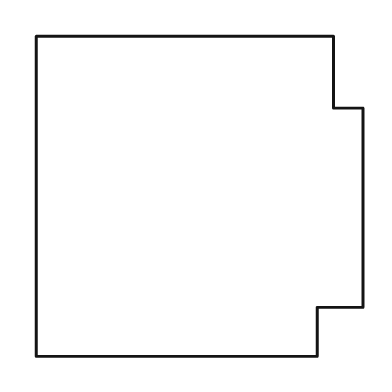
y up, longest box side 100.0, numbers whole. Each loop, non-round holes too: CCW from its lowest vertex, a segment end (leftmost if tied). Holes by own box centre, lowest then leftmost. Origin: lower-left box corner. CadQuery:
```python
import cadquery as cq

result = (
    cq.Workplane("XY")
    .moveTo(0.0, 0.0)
    .lineTo(86.0, 0.0)
    .lineTo(86.0, 15.0)
    .lineTo(100.0, 15.0)
    .lineTo(100.0, 76.0)
    .lineTo(91.0, 76.0)
    .lineTo(91.0, 98.0)
    .lineTo(0.0, 98.0)
    .close()
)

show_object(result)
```